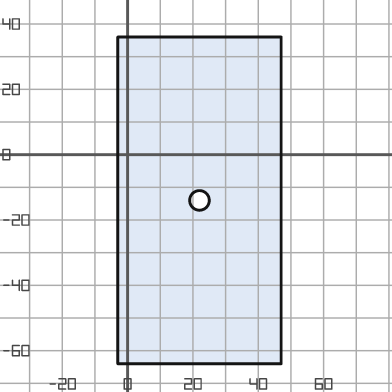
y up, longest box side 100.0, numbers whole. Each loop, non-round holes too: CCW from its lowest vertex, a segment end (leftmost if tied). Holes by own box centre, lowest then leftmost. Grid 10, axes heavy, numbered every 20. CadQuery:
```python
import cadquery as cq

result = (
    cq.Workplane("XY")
    .moveTo(-3.0, -64.0)
    .lineTo(47.0, -64.0)
    .lineTo(47.0, 36.0)
    .lineTo(-3.0, 36.0)
    .close()
    .moveTo(22.0, -14.0)
    .circle(3.0)
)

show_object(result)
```